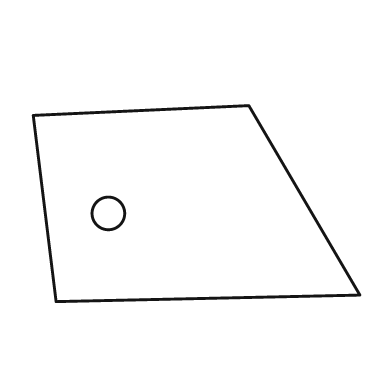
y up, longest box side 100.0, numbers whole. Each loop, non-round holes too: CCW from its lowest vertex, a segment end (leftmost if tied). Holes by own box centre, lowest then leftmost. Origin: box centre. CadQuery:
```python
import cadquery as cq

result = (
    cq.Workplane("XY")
    .moveTo(-43.0, -30.0)
    .lineTo(50.0, -28.0)
    .lineTo(16.0, 30.0)
    .lineTo(-50.0, 27.0)
    .close()
    .moveTo(-27.0, -3.0)
    .circle(5.0)
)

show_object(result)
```